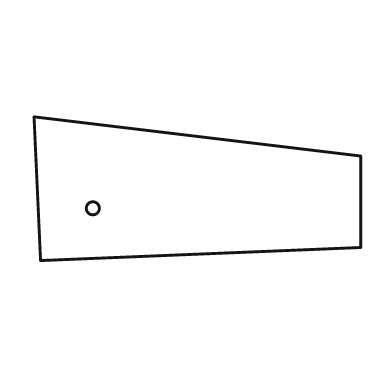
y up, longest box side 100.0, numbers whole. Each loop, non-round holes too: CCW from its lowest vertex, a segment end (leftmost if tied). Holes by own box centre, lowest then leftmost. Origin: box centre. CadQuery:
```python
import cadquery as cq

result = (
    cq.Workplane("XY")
    .moveTo(-48.0, -22.0)
    .lineTo(50.0, -18.0)
    .lineTo(50.0, 10.0)
    .lineTo(-50.0, 22.0)
    .close()
    .moveTo(-32.0, -6.0)
    .circle(2.0)
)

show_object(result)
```